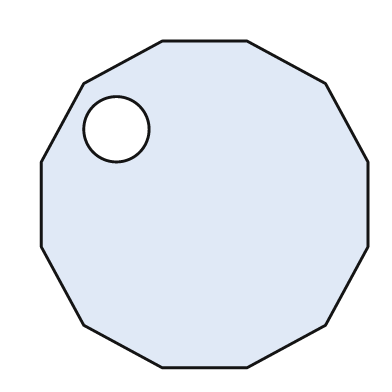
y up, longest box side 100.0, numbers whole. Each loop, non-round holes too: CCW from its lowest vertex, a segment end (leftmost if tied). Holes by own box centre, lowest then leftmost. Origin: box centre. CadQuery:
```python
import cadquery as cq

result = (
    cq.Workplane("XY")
    .moveTo(-13.0, -50.0)
    .lineTo(13.0, -50.0)
    .lineTo(37.0, -37.0)
    .lineTo(50.0, -13.0)
    .lineTo(50.0, 13.0)
    .lineTo(37.0, 37.0)
    .lineTo(13.0, 50.0)
    .lineTo(-13.0, 50.0)
    .lineTo(-37.0, 37.0)
    .lineTo(-50.0, 13.0)
    .lineTo(-50.0, -13.0)
    .lineTo(-37.0, -37.0)
    .close()
    .moveTo(-27.0, 23.0)
    .circle(10.0)
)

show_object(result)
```